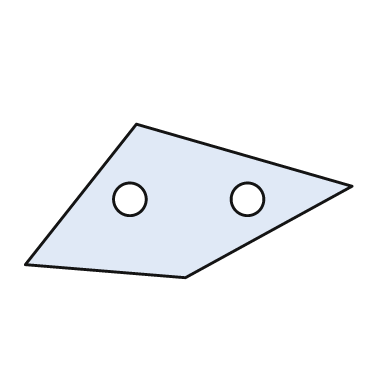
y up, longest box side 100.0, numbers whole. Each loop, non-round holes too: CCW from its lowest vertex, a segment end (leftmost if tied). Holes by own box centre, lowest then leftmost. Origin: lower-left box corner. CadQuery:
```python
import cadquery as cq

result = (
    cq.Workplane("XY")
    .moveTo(49.0, 0.0)
    .lineTo(100.0, 28.0)
    .lineTo(34.0, 47.0)
    .lineTo(0.0, 4.0)
    .close()
    .moveTo(32.0, 24.0)
    .circle(5.0)
    .moveTo(68.0, 24.0)
    .circle(5.0)
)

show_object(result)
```